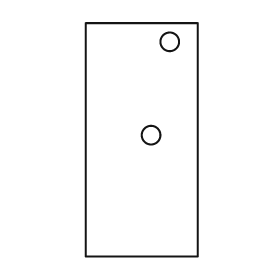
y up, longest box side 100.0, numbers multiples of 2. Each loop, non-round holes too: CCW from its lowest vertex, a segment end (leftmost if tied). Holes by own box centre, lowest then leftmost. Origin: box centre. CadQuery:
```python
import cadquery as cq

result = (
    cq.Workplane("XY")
    .moveTo(-24.0, -50.0)
    .lineTo(24.0, -50.0)
    .lineTo(24.0, 50.0)
    .lineTo(-24.0, 50.0)
    .close()
    .moveTo(4.0, 2.0)
    .circle(4.0)
    .moveTo(12.0, 42.0)
    .circle(4.0)
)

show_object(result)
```